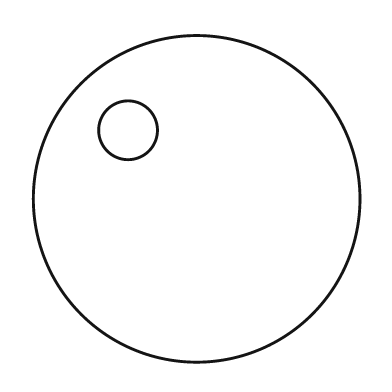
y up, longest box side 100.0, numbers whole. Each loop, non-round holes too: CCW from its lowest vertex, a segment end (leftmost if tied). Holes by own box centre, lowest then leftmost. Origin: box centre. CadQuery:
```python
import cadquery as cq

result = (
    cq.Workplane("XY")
    .moveTo(0.0, 0.0)
    .circle(50.0)
    .moveTo(-21.0, 21.0)
    .circle(9.0)
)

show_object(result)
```